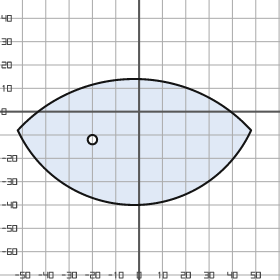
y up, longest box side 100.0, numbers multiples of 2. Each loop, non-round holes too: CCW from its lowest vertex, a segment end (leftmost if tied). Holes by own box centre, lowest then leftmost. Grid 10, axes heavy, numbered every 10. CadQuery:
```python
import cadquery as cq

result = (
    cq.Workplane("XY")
    .moveTo(-52.0, -8.0)
    .threePointArc((-2.0, -40.0), (48.0, -8.0))
    .threePointArc((-2.0, 14.0), (-52.0, -8.0))
    .close()
    .moveTo(-20.0, -12.0)
    .circle(2.0)
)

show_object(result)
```